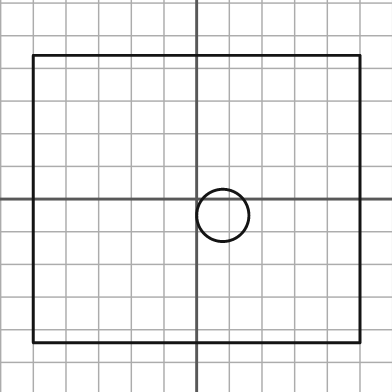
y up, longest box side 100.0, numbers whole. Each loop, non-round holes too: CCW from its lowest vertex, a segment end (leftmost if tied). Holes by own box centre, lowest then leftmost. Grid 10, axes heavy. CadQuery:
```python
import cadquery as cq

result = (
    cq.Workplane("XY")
    .moveTo(-50.0, -44.0)
    .lineTo(50.0, -44.0)
    .lineTo(50.0, 44.0)
    .lineTo(-50.0, 44.0)
    .close()
    .moveTo(8.0, -5.0)
    .circle(8.0)
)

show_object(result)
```